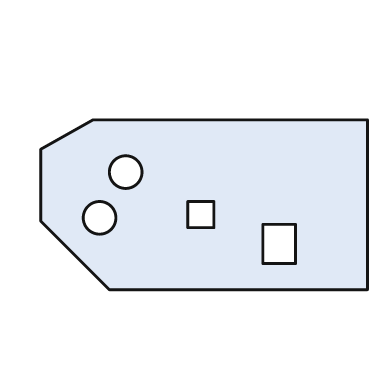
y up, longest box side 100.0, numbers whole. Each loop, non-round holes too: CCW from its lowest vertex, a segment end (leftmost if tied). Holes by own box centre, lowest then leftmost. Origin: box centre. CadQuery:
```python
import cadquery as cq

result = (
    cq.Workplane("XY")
    .moveTo(-29.0, -26.0)
    .lineTo(50.0, -26.0)
    .lineTo(50.0, 26.0)
    .lineTo(-34.0, 26.0)
    .lineTo(-50.0, 17.0)
    .lineTo(-50.0, -5.0)
    .close()
    .moveTo(18.0, -18.0)
    .lineTo(28.0, -18.0)
    .lineTo(28.0, -6.0)
    .lineTo(18.0, -6.0)
    .close()
    .moveTo(-32.0, -4.0)
    .circle(5.0)
    .moveTo(-5.0, -7.0)
    .lineTo(3.0, -7.0)
    .lineTo(3.0, 1.0)
    .lineTo(-5.0, 1.0)
    .close()
    .moveTo(-24.0, 10.0)
    .circle(5.0)
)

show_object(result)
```